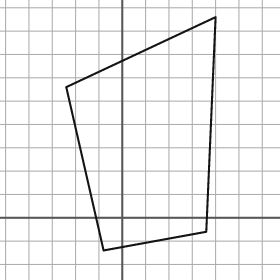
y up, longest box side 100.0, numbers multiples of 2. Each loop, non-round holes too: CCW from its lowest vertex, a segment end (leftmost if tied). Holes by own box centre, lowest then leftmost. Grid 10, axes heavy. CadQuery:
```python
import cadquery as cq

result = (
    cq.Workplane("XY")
    .moveTo(-8.0, -14.0)
    .lineTo(36.0, -6.0)
    .lineTo(40.0, 86.0)
    .lineTo(-24.0, 56.0)
    .close()
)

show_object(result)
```